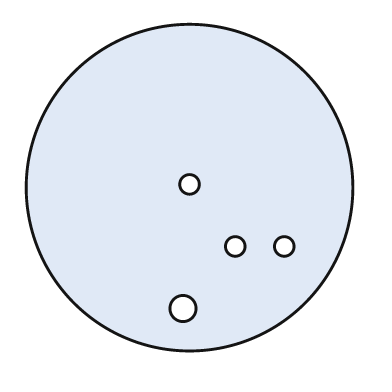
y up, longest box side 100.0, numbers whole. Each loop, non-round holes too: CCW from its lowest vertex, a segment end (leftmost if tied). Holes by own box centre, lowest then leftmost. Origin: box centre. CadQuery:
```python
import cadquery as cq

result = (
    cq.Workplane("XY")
    .moveTo(0.0, 0.0)
    .circle(50.0)
    .moveTo(-2.0, -37.0)
    .circle(4.0)
    .moveTo(14.0, -18.0)
    .circle(3.0)
    .moveTo(29.0, -18.0)
    .circle(3.0)
    .moveTo(0.0, 1.0)
    .circle(3.0)
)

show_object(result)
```